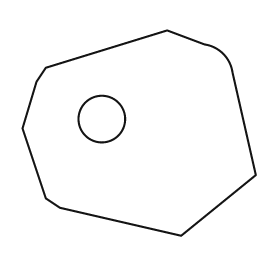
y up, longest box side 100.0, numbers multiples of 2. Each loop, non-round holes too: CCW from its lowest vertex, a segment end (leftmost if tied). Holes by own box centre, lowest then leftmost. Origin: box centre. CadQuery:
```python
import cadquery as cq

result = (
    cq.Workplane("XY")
    .moveTo(18.0, -44.0)
    .lineTo(50.0, -18.0)
    .lineTo(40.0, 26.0)
    .threePointArc((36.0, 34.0), (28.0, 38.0))
    .lineTo(12.0, 44.0)
    .lineTo(-40.0, 28.0)
    .lineTo(-44.0, 22.0)
    .lineTo(-50.0, 2.0)
    .lineTo(-40.0, -28.0)
    .lineTo(-34.0, -32.0)
    .close()
    .moveTo(-16.0, 6.0)
    .circle(10.0)
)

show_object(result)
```